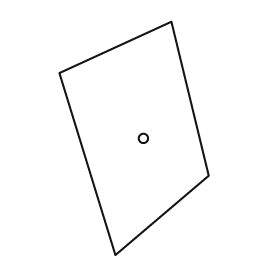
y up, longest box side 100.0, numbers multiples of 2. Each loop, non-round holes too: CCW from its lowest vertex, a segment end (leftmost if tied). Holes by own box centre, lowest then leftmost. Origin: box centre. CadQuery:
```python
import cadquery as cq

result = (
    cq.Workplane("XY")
    .moveTo(-8.0, -50.0)
    .lineTo(32.0, -16.0)
    .lineTo(16.0, 50.0)
    .lineTo(-32.0, 28.0)
    .close()
    .moveTo(4.0, 0.0)
    .circle(2.0)
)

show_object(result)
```